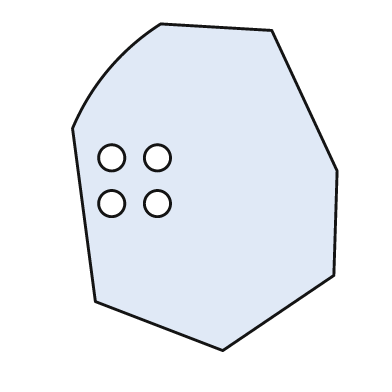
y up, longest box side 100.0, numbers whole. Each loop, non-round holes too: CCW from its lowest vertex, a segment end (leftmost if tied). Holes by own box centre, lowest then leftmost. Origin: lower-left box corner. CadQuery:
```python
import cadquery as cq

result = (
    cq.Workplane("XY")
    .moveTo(46.0, 0.0)
    .lineTo(80.0, 23.0)
    .lineTo(81.0, 55.0)
    .lineTo(61.0, 98.0)
    .lineTo(27.0, 100.0)
    .threePointArc((11.0, 86.0), (0.0, 68.0))
    .lineTo(7.0, 15.0)
    .close()
    .moveTo(12.0, 45.0)
    .circle(4.0)
    .moveTo(26.0, 45.0)
    .circle(4.0)
    .moveTo(12.0, 59.0)
    .circle(4.0)
    .moveTo(26.0, 59.0)
    .circle(4.0)
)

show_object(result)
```